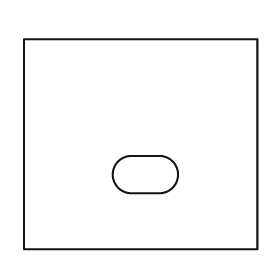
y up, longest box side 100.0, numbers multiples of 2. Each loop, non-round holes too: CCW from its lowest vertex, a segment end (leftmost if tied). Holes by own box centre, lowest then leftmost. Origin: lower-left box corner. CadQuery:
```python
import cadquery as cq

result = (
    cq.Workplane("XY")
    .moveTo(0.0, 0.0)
    .lineTo(100.0, 0.0)
    .lineTo(100.0, 90.0)
    .lineTo(0.0, 90.0)
    .close()
    .moveTo(46.0, 24.0)
    .lineTo(58.0, 24.0)
    .threePointArc((66.0, 32.0), (58.0, 40.0))
    .lineTo(46.0, 40.0)
    .threePointArc((38.0, 32.0), (46.0, 24.0))
    .close()
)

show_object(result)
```